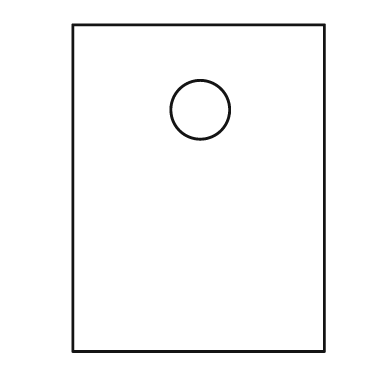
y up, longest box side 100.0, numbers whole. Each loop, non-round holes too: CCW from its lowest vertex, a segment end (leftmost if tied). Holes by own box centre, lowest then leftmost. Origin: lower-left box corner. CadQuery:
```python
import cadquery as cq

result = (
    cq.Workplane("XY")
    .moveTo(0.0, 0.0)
    .lineTo(77.0, 0.0)
    .lineTo(77.0, 100.0)
    .lineTo(0.0, 100.0)
    .close()
    .moveTo(39.0, 74.0)
    .circle(9.0)
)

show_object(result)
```